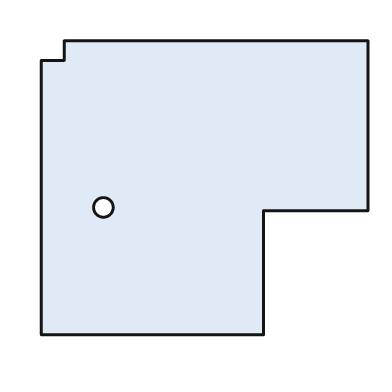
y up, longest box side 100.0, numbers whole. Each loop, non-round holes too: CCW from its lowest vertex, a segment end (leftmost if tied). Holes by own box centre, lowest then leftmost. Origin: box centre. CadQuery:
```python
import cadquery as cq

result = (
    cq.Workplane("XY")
    .moveTo(-50.0, -45.0)
    .lineTo(18.0, -45.0)
    .lineTo(18.0, -7.0)
    .lineTo(50.0, -7.0)
    .lineTo(50.0, 45.0)
    .lineTo(-43.0, 45.0)
    .lineTo(-43.0, 39.0)
    .lineTo(-50.0, 39.0)
    .close()
    .moveTo(-31.0, -6.0)
    .circle(3.0)
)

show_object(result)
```